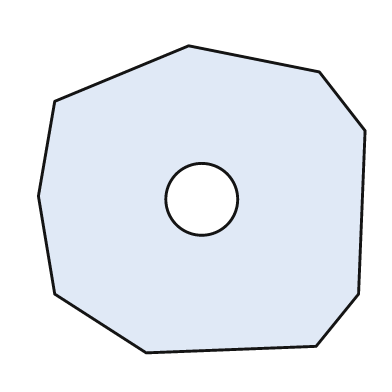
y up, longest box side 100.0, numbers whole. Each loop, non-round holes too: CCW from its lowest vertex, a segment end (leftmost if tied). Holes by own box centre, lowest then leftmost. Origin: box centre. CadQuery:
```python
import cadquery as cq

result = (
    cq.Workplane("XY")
    .moveTo(-17.0, -47.0)
    .lineTo(35.0, -45.0)
    .lineTo(48.0, -29.0)
    .lineTo(50.0, 21.0)
    .lineTo(36.0, 39.0)
    .lineTo(-4.0, 47.0)
    .lineTo(-45.0, 30.0)
    .lineTo(-50.0, 1.0)
    .lineTo(-45.0, -29.0)
    .close()
    .moveTo(0.0, 0.0)
    .circle(11.0)
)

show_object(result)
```